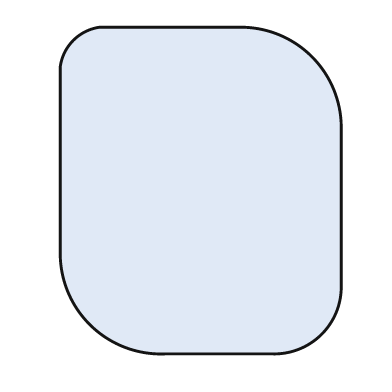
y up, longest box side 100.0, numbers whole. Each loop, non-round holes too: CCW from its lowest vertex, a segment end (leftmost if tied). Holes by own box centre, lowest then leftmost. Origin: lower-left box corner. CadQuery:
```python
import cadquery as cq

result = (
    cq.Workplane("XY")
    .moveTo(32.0, 0.0)
    .lineTo(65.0, 0.0)
    .threePointArc((80.0, 6.0), (86.0, 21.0))
    .lineTo(86.0, 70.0)
    .threePointArc((77.0, 91.0), (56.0, 100.0))
    .lineTo(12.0, 100.0)
    .threePointArc((4.0, 96.0), (0.0, 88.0))
    .lineTo(0.0, 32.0)
    .threePointArc((9.0, 9.0), (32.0, 0.0))
    .close()
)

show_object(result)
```